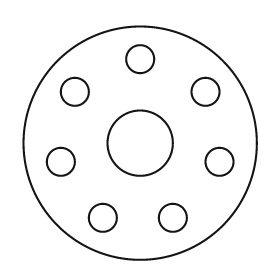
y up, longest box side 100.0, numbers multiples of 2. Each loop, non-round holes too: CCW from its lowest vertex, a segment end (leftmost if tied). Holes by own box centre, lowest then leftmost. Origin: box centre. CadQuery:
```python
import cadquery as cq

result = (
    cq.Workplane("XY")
    .moveTo(0.0, 0.0)
    .circle(50.0)
    .moveTo(-16.0, -32.0)
    .circle(6.0)
    .moveTo(14.0, -32.0)
    .circle(6.0)
    .moveTo(-34.0, -8.0)
    .circle(6.0)
    .moveTo(34.0, -8.0)
    .circle(6.0)
    .moveTo(0.0, 0.0)
    .circle(14.0)
    .moveTo(-28.0, 22.0)
    .circle(6.0)
    .moveTo(28.0, 22.0)
    .circle(6.0)
    .moveTo(0.0, 36.0)
    .circle(6.0)
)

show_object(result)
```